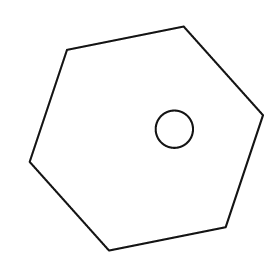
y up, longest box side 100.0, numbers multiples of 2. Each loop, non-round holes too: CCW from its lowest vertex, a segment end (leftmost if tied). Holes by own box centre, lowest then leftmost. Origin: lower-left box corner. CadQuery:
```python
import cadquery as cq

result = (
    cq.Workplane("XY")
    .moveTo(34.0, 0.0)
    .lineTo(84.0, 10.0)
    .lineTo(100.0, 58.0)
    .lineTo(66.0, 96.0)
    .lineTo(16.0, 86.0)
    .lineTo(0.0, 38.0)
    .close()
    .moveTo(62.0, 52.0)
    .circle(8.0)
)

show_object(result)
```